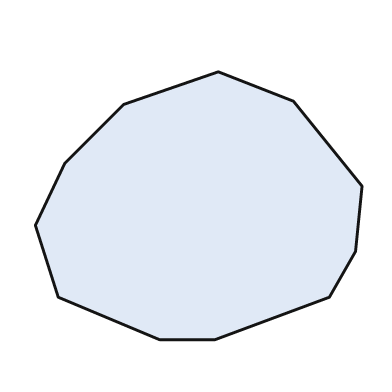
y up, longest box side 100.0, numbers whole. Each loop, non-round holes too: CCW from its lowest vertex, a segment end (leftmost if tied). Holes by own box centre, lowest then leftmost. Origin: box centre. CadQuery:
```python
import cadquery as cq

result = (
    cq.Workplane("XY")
    .moveTo(-12.0, -41.0)
    .lineTo(5.0, -41.0)
    .lineTo(40.0, -28.0)
    .lineTo(48.0, -14.0)
    .lineTo(50.0, 6.0)
    .lineTo(29.0, 32.0)
    .lineTo(6.0, 41.0)
    .lineTo(-23.0, 31.0)
    .lineTo(-41.0, 13.0)
    .lineTo(-50.0, -6.0)
    .lineTo(-43.0, -28.0)
    .close()
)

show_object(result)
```